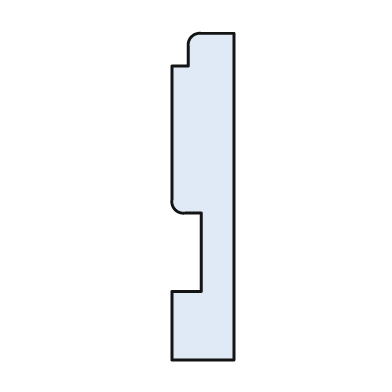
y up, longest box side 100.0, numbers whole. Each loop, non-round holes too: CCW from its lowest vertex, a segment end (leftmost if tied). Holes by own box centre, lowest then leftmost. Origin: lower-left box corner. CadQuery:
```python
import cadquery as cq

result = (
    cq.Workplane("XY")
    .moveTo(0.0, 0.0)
    .lineTo(19.0, 0.0)
    .lineTo(19.0, 100.0)
    .lineTo(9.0, 100.0)
    .threePointArc((6.0, 99.0), (5.0, 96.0))
    .lineTo(5.0, 90.0)
    .lineTo(0.0, 90.0)
    .lineTo(0.0, 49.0)
    .threePointArc((1.0, 46.0), (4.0, 45.0))
    .lineTo(9.0, 45.0)
    .lineTo(9.0, 21.0)
    .lineTo(0.0, 21.0)
    .close()
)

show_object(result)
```